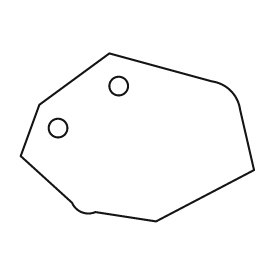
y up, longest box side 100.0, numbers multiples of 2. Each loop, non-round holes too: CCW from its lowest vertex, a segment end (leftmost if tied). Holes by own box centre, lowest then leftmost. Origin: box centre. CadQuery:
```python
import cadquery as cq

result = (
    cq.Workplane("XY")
    .moveTo(8.0, -36.0)
    .lineTo(50.0, -14.0)
    .lineTo(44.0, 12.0)
    .threePointArc((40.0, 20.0), (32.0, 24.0))
    .lineTo(-12.0, 36.0)
    .lineTo(-42.0, 14.0)
    .lineTo(-50.0, -8.0)
    .lineTo(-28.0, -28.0)
    .threePointArc((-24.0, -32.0), (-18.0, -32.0))
    .close()
    .moveTo(-34.0, 4.0)
    .circle(4.0)
    .moveTo(-8.0, 22.0)
    .circle(4.0)
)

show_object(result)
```